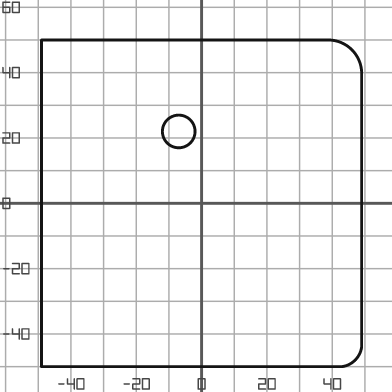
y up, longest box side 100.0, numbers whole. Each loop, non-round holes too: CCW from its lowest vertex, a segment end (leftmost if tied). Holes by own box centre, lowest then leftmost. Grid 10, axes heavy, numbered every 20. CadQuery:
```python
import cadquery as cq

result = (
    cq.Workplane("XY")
    .moveTo(-49.0, -50.0)
    .lineTo(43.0, -50.0)
    .threePointArc((47.0, -48.0), (49.0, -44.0))
    .lineTo(49.0, 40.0)
    .threePointArc((46.0, 47.0), (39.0, 50.0))
    .lineTo(-49.0, 50.0)
    .close()
    .moveTo(-7.0, 22.0)
    .circle(5.0)
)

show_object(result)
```